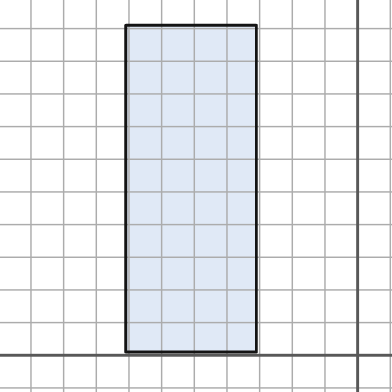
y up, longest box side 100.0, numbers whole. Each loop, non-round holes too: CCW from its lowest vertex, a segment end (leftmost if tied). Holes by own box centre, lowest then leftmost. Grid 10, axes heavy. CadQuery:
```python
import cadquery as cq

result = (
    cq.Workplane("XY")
    .moveTo(-71.0, 1.0)
    .lineTo(-31.0, 1.0)
    .lineTo(-31.0, 101.0)
    .lineTo(-71.0, 101.0)
    .close()
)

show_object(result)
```